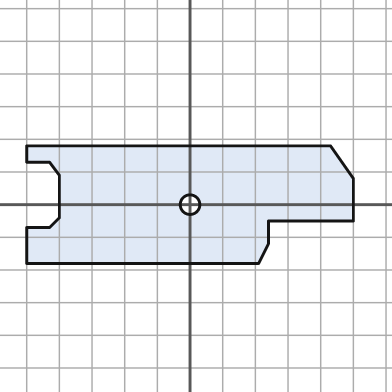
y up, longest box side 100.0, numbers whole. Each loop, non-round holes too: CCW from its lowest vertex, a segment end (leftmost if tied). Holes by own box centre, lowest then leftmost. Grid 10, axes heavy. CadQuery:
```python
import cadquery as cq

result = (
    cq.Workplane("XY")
    .moveTo(-50.0, -18.0)
    .lineTo(21.0, -18.0)
    .lineTo(24.0, -12.0)
    .lineTo(24.0, -5.0)
    .lineTo(50.0, -5.0)
    .lineTo(50.0, 8.0)
    .lineTo(43.0, 18.0)
    .lineTo(-50.0, 18.0)
    .lineTo(-50.0, 13.0)
    .lineTo(-43.0, 13.0)
    .lineTo(-40.0, 9.0)
    .lineTo(-40.0, -4.0)
    .lineTo(-43.0, -7.0)
    .lineTo(-50.0, -7.0)
    .close()
    .moveTo(0.0, 0.0)
    .circle(3.0)
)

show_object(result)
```